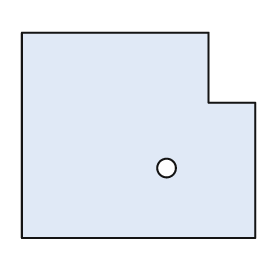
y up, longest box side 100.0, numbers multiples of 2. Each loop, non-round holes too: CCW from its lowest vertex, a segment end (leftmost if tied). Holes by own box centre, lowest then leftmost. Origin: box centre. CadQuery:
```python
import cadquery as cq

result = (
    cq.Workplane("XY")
    .moveTo(-50.0, -44.0)
    .lineTo(50.0, -44.0)
    .lineTo(50.0, 14.0)
    .lineTo(30.0, 14.0)
    .lineTo(30.0, 44.0)
    .lineTo(-50.0, 44.0)
    .close()
    .moveTo(12.0, -14.0)
    .circle(4.0)
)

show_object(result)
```